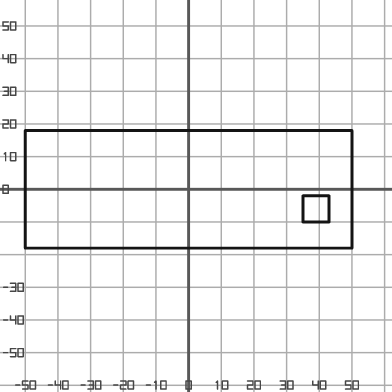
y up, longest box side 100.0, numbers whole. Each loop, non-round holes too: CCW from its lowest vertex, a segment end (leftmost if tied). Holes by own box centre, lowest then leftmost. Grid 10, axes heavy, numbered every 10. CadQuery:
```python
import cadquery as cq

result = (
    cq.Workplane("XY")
    .moveTo(-50.0, -18.0)
    .lineTo(50.0, -18.0)
    .lineTo(50.0, 18.0)
    .lineTo(-50.0, 18.0)
    .close()
    .moveTo(35.0, -10.0)
    .lineTo(43.0, -10.0)
    .lineTo(43.0, -2.0)
    .lineTo(35.0, -2.0)
    .close()
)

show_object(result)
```